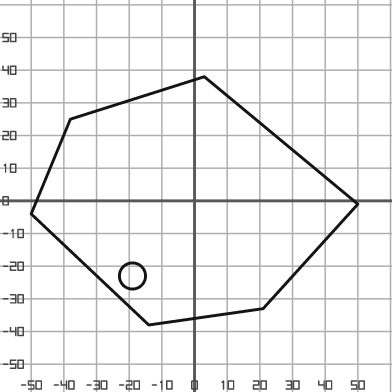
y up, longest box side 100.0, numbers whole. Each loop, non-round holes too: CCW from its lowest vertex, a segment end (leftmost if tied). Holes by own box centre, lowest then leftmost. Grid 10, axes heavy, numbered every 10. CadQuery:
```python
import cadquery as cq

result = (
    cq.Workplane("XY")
    .moveTo(-14.0, -38.0)
    .lineTo(21.0, -33.0)
    .lineTo(50.0, -1.0)
    .lineTo(3.0, 38.0)
    .lineTo(-38.0, 25.0)
    .lineTo(-50.0, -4.0)
    .close()
    .moveTo(-19.0, -23.0)
    .circle(4.0)
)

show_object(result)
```